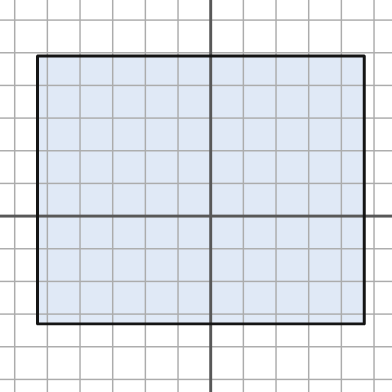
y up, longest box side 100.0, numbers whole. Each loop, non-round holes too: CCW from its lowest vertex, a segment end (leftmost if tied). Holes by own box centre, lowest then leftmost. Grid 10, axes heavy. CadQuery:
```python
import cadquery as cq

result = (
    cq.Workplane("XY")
    .moveTo(-53.0, -33.0)
    .lineTo(47.0, -33.0)
    .lineTo(47.0, 49.0)
    .lineTo(-53.0, 49.0)
    .close()
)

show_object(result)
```